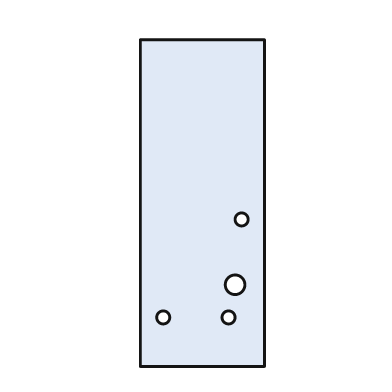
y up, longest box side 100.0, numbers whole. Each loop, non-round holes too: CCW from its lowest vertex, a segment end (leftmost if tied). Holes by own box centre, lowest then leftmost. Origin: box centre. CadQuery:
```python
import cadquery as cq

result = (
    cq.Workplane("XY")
    .moveTo(-19.0, -50.0)
    .lineTo(19.0, -50.0)
    .lineTo(19.0, 50.0)
    .lineTo(-19.0, 50.0)
    .close()
    .moveTo(-12.0, -35.0)
    .circle(2.0)
    .moveTo(8.0, -35.0)
    .circle(2.0)
    .moveTo(10.0, -25.0)
    .circle(3.0)
    .moveTo(12.0, -5.0)
    .circle(2.0)
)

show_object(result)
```